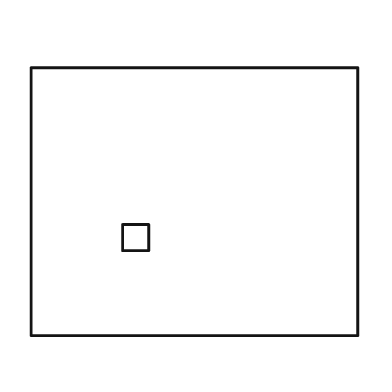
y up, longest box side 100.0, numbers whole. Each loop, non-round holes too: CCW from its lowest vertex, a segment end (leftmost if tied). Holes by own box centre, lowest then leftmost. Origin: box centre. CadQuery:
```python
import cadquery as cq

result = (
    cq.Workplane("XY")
    .moveTo(-50.0, -41.0)
    .lineTo(50.0, -41.0)
    .lineTo(50.0, 41.0)
    .lineTo(-50.0, 41.0)
    .close()
    .moveTo(-22.0, -15.0)
    .lineTo(-14.0, -15.0)
    .lineTo(-14.0, -7.0)
    .lineTo(-22.0, -7.0)
    .close()
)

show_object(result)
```